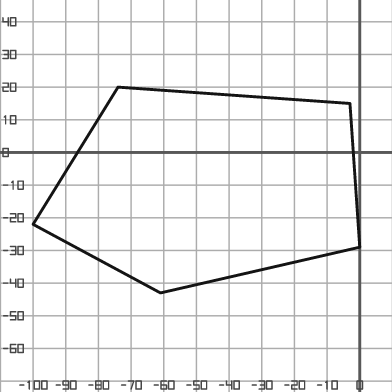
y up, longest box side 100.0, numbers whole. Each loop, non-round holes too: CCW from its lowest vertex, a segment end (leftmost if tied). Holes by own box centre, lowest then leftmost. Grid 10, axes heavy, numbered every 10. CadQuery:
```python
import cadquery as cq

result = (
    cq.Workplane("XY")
    .moveTo(-61.0, -43.0)
    .lineTo(0.0, -29.0)
    .lineTo(-3.0, 15.0)
    .lineTo(-74.0, 20.0)
    .lineTo(-100.0, -22.0)
    .close()
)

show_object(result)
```